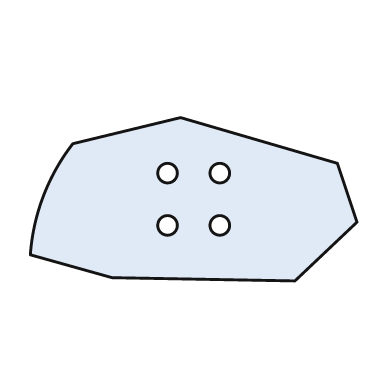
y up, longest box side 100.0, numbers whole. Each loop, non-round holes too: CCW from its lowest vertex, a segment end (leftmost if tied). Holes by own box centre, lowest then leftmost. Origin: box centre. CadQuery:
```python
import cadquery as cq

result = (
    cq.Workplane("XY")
    .moveTo(31.0, -25.0)
    .lineTo(50.0, -7.0)
    .lineTo(44.0, 11.0)
    .lineTo(-4.0, 25.0)
    .lineTo(-37.0, 17.0)
    .threePointArc((-46.0, 1.0), (-50.0, -17.0))
    .lineTo(-25.0, -24.0)
    .close()
    .moveTo(-8.0, -8.0)
    .circle(3.0)
    .moveTo(8.0, -8.0)
    .circle(3.0)
    .moveTo(-8.0, 8.0)
    .circle(3.0)
    .moveTo(8.0, 8.0)
    .circle(3.0)
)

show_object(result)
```